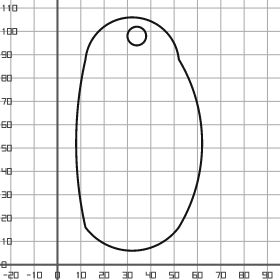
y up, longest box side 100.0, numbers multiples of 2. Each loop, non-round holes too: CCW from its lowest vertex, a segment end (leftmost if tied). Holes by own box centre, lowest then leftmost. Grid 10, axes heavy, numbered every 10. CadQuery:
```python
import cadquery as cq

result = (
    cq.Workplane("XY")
    .moveTo(12.0, 16.0)
    .threePointArc((32.0, 6.0), (52.0, 16.0))
    .threePointArc((62.0, 52.0), (52.0, 88.0))
    .threePointArc((32.0, 106.0), (12.0, 88.0))
    .threePointArc((8.0, 52.0), (12.0, 16.0))
    .close()
    .moveTo(34.0, 98.0)
    .circle(4.0)
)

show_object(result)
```